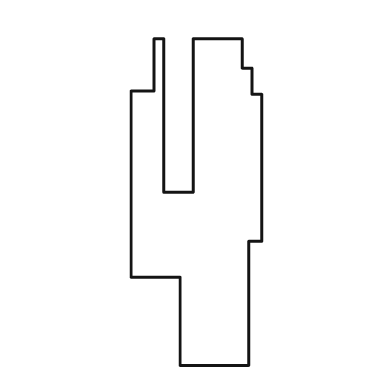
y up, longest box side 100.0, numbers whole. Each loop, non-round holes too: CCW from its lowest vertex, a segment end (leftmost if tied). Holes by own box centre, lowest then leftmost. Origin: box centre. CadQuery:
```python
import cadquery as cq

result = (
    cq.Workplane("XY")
    .moveTo(-5.0, -50.0)
    .lineTo(16.0, -50.0)
    .lineTo(16.0, -12.0)
    .lineTo(20.0, -12.0)
    .lineTo(20.0, 33.0)
    .lineTo(17.0, 33.0)
    .lineTo(17.0, 41.0)
    .lineTo(14.0, 41.0)
    .lineTo(14.0, 50.0)
    .lineTo(-1.0, 50.0)
    .lineTo(-1.0, 3.0)
    .lineTo(-10.0, 3.0)
    .lineTo(-10.0, 50.0)
    .lineTo(-13.0, 50.0)
    .lineTo(-13.0, 34.0)
    .lineTo(-20.0, 34.0)
    .lineTo(-20.0, -23.0)
    .lineTo(-5.0, -23.0)
    .close()
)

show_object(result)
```